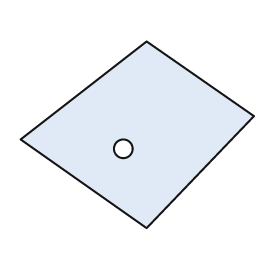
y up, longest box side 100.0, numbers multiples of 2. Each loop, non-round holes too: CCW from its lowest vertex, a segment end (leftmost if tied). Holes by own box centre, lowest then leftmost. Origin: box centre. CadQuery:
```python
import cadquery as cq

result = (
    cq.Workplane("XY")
    .moveTo(4.0, -40.0)
    .lineTo(50.0, 8.0)
    .lineTo(4.0, 40.0)
    .lineTo(-50.0, -2.0)
    .close()
    .moveTo(-6.0, -6.0)
    .circle(4.0)
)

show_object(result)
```